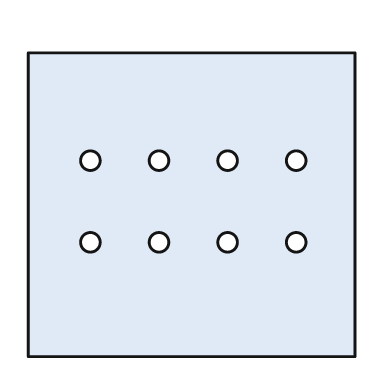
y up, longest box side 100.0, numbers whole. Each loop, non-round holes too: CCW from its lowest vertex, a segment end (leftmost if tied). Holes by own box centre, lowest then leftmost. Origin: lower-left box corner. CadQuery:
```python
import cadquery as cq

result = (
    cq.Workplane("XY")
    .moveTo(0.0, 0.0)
    .lineTo(100.0, 0.0)
    .lineTo(100.0, 93.0)
    .lineTo(0.0, 93.0)
    .close()
    .moveTo(19.0, 35.0)
    .circle(3.0)
    .moveTo(40.0, 35.0)
    .circle(3.0)
    .moveTo(61.0, 35.0)
    .circle(3.0)
    .moveTo(82.0, 35.0)
    .circle(3.0)
    .moveTo(19.0, 60.0)
    .circle(3.0)
    .moveTo(40.0, 60.0)
    .circle(3.0)
    .moveTo(61.0, 60.0)
    .circle(3.0)
    .moveTo(82.0, 60.0)
    .circle(3.0)
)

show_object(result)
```